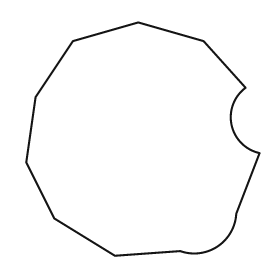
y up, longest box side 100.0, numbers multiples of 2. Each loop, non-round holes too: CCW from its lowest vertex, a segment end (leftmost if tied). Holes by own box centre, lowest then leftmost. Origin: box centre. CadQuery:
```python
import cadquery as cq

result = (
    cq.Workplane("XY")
    .moveTo(-12.0, -50.0)
    .lineTo(16.0, -48.0)
    .threePointArc((32.0, -46.0), (40.0, -32.0))
    .lineTo(50.0, -6.0)
    .threePointArc((38.0, 6.0), (44.0, 22.0))
    .lineTo(26.0, 42.0)
    .lineTo(-2.0, 50.0)
    .lineTo(-30.0, 42.0)
    .lineTo(-46.0, 18.0)
    .lineTo(-50.0, -10.0)
    .lineTo(-38.0, -34.0)
    .close()
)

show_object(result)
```